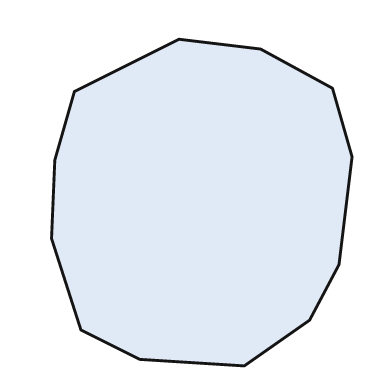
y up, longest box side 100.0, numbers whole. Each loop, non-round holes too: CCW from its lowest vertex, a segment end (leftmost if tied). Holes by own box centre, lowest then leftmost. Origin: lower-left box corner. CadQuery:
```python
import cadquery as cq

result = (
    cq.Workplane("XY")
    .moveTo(59.0, 0.0)
    .lineTo(79.0, 14.0)
    .lineTo(88.0, 31.0)
    .lineTo(92.0, 64.0)
    .lineTo(86.0, 85.0)
    .lineTo(64.0, 97.0)
    .lineTo(39.0, 100.0)
    .lineTo(7.0, 84.0)
    .lineTo(1.0, 63.0)
    .lineTo(0.0, 39.0)
    .lineTo(9.0, 11.0)
    .lineTo(27.0, 2.0)
    .close()
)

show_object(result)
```